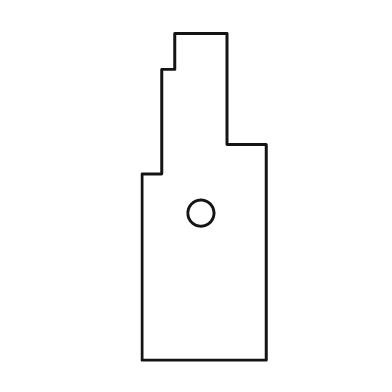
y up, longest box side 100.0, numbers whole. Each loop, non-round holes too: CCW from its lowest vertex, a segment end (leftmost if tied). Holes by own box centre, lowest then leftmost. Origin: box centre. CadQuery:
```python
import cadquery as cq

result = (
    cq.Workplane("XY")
    .moveTo(-19.0, -50.0)
    .lineTo(19.0, -50.0)
    .lineTo(19.0, 16.0)
    .lineTo(7.0, 16.0)
    .lineTo(7.0, 50.0)
    .lineTo(-9.0, 50.0)
    .lineTo(-9.0, 39.0)
    .lineTo(-13.0, 39.0)
    .lineTo(-13.0, 7.0)
    .lineTo(-19.0, 7.0)
    .close()
    .moveTo(-1.0, -5.0)
    .circle(4.0)
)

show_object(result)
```